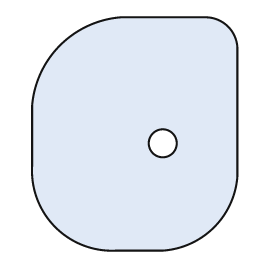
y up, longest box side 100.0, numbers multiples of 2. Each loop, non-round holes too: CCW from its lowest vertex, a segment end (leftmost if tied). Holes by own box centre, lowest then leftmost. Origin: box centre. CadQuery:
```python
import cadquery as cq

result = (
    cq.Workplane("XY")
    .moveTo(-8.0, -50.0)
    .lineTo(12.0, -50.0)
    .threePointArc((34.0, -40.0), (44.0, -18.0))
    .lineTo(44.0, 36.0)
    .threePointArc((40.0, 46.0), (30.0, 50.0))
    .lineTo(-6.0, 50.0)
    .threePointArc((-32.0, 38.0), (-44.0, 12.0))
    .lineTo(-44.0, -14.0)
    .threePointArc((-34.0, -40.0), (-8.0, -50.0))
    .close()
    .moveTo(12.0, -4.0)
    .circle(6.0)
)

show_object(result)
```